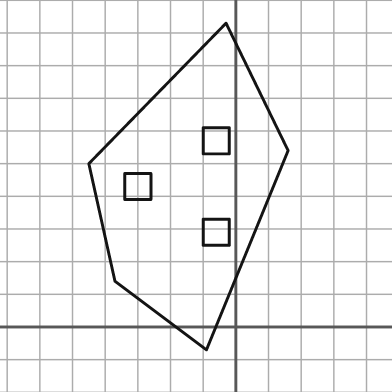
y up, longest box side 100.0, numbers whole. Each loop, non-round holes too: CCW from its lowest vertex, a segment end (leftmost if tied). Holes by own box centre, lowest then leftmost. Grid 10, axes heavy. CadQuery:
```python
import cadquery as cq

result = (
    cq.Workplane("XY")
    .moveTo(-9.0, -7.0)
    .lineTo(16.0, 54.0)
    .lineTo(-3.0, 93.0)
    .lineTo(-45.0, 50.0)
    .lineTo(-37.0, 14.0)
    .close()
    .moveTo(-10.0, 25.0)
    .lineTo(-2.0, 25.0)
    .lineTo(-2.0, 33.0)
    .lineTo(-10.0, 33.0)
    .close()
    .moveTo(-34.0, 39.0)
    .lineTo(-26.0, 39.0)
    .lineTo(-26.0, 47.0)
    .lineTo(-34.0, 47.0)
    .close()
    .moveTo(-10.0, 53.0)
    .lineTo(-2.0, 53.0)
    .lineTo(-2.0, 61.0)
    .lineTo(-10.0, 61.0)
    .close()
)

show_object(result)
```